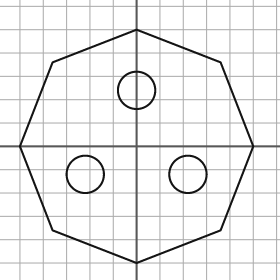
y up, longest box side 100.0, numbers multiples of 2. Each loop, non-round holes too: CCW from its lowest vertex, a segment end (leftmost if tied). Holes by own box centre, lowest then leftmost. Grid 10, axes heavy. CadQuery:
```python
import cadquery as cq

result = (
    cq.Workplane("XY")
    .moveTo(0.0, -50.0)
    .lineTo(36.0, -36.0)
    .lineTo(50.0, 0.0)
    .lineTo(36.0, 36.0)
    .lineTo(0.0, 50.0)
    .lineTo(-36.0, 36.0)
    .lineTo(-50.0, 0.0)
    .lineTo(-36.0, -36.0)
    .close()
    .moveTo(-22.0, -12.0)
    .circle(8.0)
    .moveTo(22.0, -12.0)
    .circle(8.0)
    .moveTo(0.0, 24.0)
    .circle(8.0)
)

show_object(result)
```